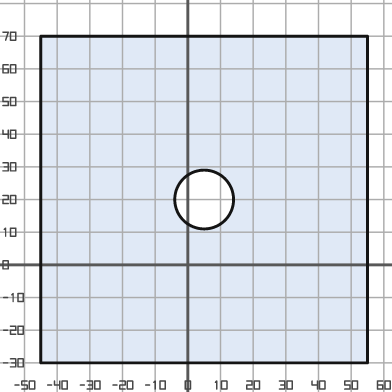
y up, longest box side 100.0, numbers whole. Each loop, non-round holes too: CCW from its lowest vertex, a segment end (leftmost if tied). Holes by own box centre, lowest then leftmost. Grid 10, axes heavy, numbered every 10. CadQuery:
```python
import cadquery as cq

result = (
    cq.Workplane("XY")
    .moveTo(-45.0, -30.0)
    .lineTo(55.0, -30.0)
    .lineTo(55.0, 70.0)
    .lineTo(-45.0, 70.0)
    .close()
    .moveTo(5.0, 20.0)
    .circle(9.0)
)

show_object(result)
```